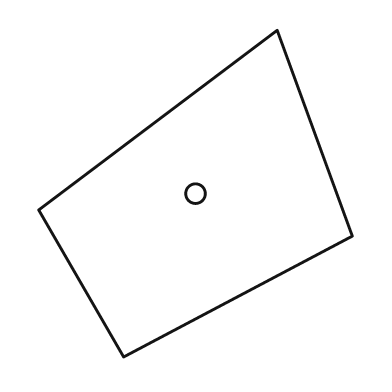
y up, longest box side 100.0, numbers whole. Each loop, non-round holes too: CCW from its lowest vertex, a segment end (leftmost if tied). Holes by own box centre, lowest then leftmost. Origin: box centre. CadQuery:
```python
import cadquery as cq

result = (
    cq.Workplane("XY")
    .moveTo(-22.0, -50.0)
    .lineTo(48.0, -13.0)
    .lineTo(25.0, 50.0)
    .lineTo(-48.0, -5.0)
    .close()
    .moveTo(0.0, 0.0)
    .circle(3.0)
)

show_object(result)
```